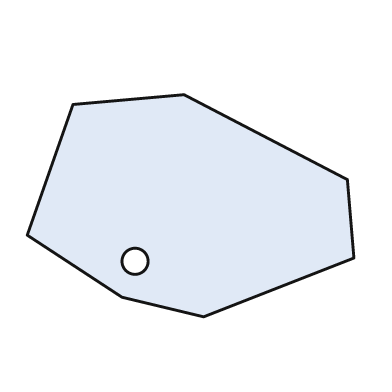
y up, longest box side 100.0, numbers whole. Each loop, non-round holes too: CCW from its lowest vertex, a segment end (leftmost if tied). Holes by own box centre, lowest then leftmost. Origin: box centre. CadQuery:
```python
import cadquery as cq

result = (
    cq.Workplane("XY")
    .moveTo(4.0, -34.0)
    .lineTo(50.0, -16.0)
    .lineTo(48.0, 8.0)
    .lineTo(-2.0, 34.0)
    .lineTo(-36.0, 31.0)
    .lineTo(-50.0, -9.0)
    .lineTo(-21.0, -28.0)
    .close()
    .moveTo(-17.0, -17.0)
    .circle(4.0)
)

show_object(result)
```